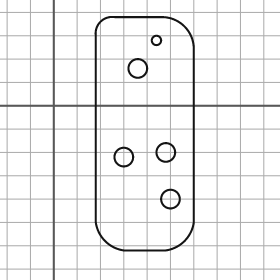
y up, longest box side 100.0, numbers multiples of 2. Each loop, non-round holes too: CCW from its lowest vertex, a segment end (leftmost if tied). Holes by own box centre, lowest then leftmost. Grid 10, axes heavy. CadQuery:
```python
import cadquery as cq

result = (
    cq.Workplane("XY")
    .moveTo(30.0, -62.0)
    .lineTo(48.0, -62.0)
    .threePointArc((56.0, -58.0), (60.0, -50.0))
    .lineTo(60.0, 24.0)
    .threePointArc((56.0, 34.0), (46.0, 38.0))
    .lineTo(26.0, 38.0)
    .threePointArc((20.0, 36.0), (18.0, 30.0))
    .lineTo(18.0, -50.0)
    .threePointArc((22.0, -58.0), (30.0, -62.0))
    .close()
    .moveTo(50.0, -40.0)
    .circle(4.0)
    .moveTo(30.0, -22.0)
    .circle(4.0)
    .moveTo(48.0, -20.0)
    .circle(4.0)
    .moveTo(36.0, 16.0)
    .circle(4.0)
    .moveTo(44.0, 28.0)
    .circle(2.0)
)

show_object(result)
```